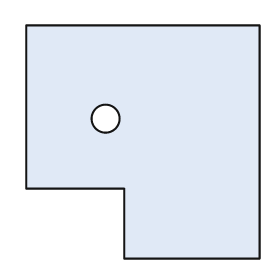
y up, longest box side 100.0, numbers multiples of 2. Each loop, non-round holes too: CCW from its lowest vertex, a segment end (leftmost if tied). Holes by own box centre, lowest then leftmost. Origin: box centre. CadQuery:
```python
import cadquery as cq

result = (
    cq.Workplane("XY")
    .moveTo(-8.0, -50.0)
    .lineTo(50.0, -50.0)
    .lineTo(50.0, 50.0)
    .lineTo(-50.0, 50.0)
    .lineTo(-50.0, -20.0)
    .lineTo(-8.0, -20.0)
    .close()
    .moveTo(-16.0, 10.0)
    .circle(6.0)
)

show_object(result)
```